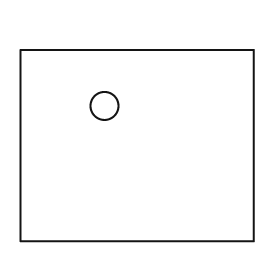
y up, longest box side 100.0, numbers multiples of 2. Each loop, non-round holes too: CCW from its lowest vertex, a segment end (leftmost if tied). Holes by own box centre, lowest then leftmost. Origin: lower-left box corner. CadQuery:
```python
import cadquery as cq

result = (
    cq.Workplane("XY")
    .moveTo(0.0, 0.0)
    .lineTo(100.0, 0.0)
    .lineTo(100.0, 82.0)
    .lineTo(0.0, 82.0)
    .close()
    .moveTo(36.0, 58.0)
    .circle(6.0)
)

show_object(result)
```